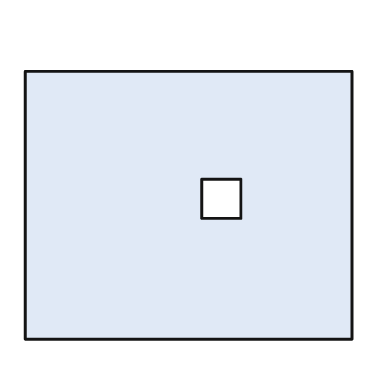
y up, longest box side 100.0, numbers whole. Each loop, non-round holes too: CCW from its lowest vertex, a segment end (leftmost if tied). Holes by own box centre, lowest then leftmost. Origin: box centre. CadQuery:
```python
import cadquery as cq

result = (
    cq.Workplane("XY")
    .moveTo(-50.0, -41.0)
    .lineTo(50.0, -41.0)
    .lineTo(50.0, 41.0)
    .lineTo(-50.0, 41.0)
    .close()
    .moveTo(4.0, -4.0)
    .lineTo(16.0, -4.0)
    .lineTo(16.0, 8.0)
    .lineTo(4.0, 8.0)
    .close()
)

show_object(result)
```